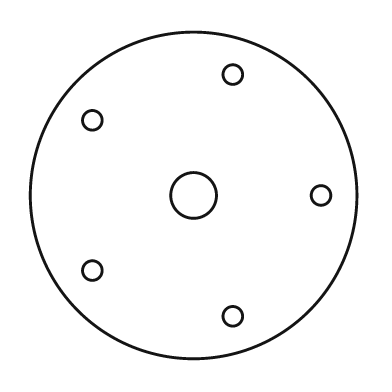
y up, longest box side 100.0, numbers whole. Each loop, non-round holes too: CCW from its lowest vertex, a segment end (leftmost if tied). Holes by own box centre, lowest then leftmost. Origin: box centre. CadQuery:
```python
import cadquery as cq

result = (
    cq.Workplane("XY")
    .moveTo(0.0, 0.0)
    .circle(50.0)
    .moveTo(12.0, -37.0)
    .circle(3.0)
    .moveTo(-31.0, -23.0)
    .circle(3.0)
    .moveTo(0.0, 0.0)
    .circle(7.0)
    .moveTo(39.0, 0.0)
    .circle(3.0)
    .moveTo(-31.0, 23.0)
    .circle(3.0)
    .moveTo(12.0, 37.0)
    .circle(3.0)
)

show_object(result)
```